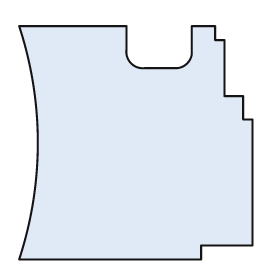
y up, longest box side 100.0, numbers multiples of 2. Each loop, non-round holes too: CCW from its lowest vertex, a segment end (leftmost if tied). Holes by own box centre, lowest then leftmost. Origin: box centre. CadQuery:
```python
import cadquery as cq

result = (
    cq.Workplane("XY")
    .moveTo(-50.0, -50.0)
    .lineTo(28.0, -50.0)
    .lineTo(28.0, -44.0)
    .lineTo(50.0, -44.0)
    .lineTo(50.0, 10.0)
    .lineTo(46.0, 10.0)
    .lineTo(46.0, 20.0)
    .lineTo(38.0, 20.0)
    .lineTo(38.0, 44.0)
    .lineTo(34.0, 44.0)
    .lineTo(34.0, 50.0)
    .lineTo(24.0, 50.0)
    .lineTo(24.0, 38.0)
    .threePointArc((22.0, 34.0), (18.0, 32.0))
    .lineTo(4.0, 32.0)
    .threePointArc((-2.0, 34.0), (-4.0, 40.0))
    .lineTo(-4.0, 50.0)
    .lineTo(-50.0, 50.0)
    .threePointArc((-42.0, 0.0), (-50.0, -50.0))
    .close()
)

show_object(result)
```